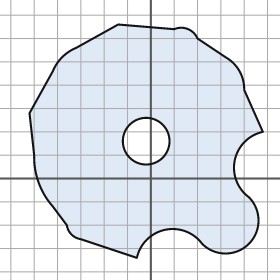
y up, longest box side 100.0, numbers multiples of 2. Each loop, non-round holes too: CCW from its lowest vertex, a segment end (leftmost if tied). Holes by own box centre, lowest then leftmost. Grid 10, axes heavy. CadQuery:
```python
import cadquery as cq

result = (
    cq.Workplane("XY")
    .moveTo(-6.0, -34.0)
    .threePointArc((6.0, -22.0), (22.0, -28.0))
    .threePointArc((42.0, -28.0), (42.0, -8.0))
    .threePointArc((36.0, 8.0), (48.0, 20.0))
    .lineTo(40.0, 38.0)
    .threePointArc((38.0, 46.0), (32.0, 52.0))
    .lineTo(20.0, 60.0)
    .threePointArc((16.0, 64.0), (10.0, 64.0))
    .lineTo(-14.0, 66.0)
    .lineTo(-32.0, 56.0)
    .threePointArc((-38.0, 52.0), (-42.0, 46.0))
    .lineTo(-52.0, 28.0)
    .lineTo(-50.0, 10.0)
    .threePointArc((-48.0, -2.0), (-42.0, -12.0))
    .lineTo(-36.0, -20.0)
    .threePointArc((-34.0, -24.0), (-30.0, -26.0))
    .close()
    .moveTo(-2.0, 16.0)
    .circle(10.0)
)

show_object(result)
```